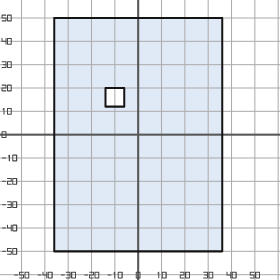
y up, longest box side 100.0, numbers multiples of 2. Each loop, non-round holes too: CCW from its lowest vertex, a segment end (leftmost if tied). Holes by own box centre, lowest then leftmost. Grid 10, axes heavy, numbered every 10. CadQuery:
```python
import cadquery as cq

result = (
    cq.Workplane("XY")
    .moveTo(-36.0, -50.0)
    .lineTo(36.0, -50.0)
    .lineTo(36.0, 50.0)
    .lineTo(-36.0, 50.0)
    .close()
    .moveTo(-14.0, 12.0)
    .lineTo(-6.0, 12.0)
    .lineTo(-6.0, 20.0)
    .lineTo(-14.0, 20.0)
    .close()
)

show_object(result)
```